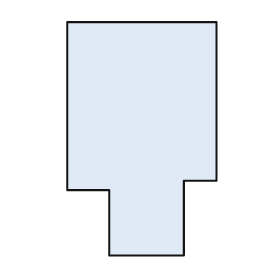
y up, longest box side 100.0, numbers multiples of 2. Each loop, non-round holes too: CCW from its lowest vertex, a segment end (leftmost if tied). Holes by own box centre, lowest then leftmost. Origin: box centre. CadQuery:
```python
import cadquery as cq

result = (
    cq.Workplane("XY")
    .moveTo(-14.0, -50.0)
    .lineTo(18.0, -50.0)
    .lineTo(18.0, -18.0)
    .lineTo(32.0, -18.0)
    .lineTo(32.0, 50.0)
    .lineTo(-32.0, 50.0)
    .lineTo(-32.0, -22.0)
    .lineTo(-14.0, -22.0)
    .close()
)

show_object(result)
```